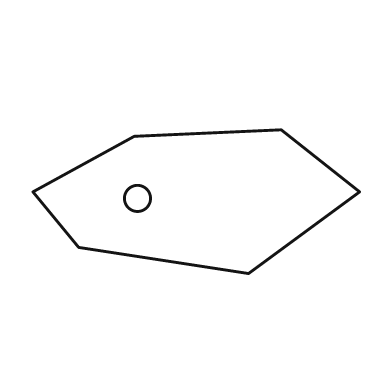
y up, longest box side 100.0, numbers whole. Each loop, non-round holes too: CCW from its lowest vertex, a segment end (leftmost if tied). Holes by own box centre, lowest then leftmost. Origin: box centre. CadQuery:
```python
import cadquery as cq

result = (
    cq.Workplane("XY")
    .moveTo(16.0, -22.0)
    .lineTo(50.0, 3.0)
    .lineTo(26.0, 22.0)
    .lineTo(-19.0, 20.0)
    .lineTo(-50.0, 3.0)
    .lineTo(-36.0, -14.0)
    .close()
    .moveTo(-18.0, 1.0)
    .circle(4.0)
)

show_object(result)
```